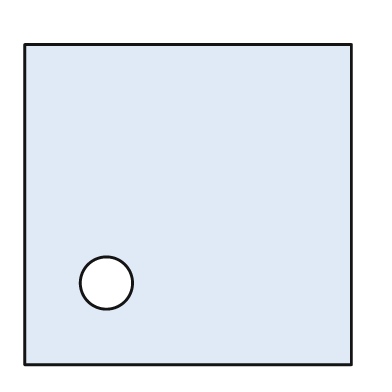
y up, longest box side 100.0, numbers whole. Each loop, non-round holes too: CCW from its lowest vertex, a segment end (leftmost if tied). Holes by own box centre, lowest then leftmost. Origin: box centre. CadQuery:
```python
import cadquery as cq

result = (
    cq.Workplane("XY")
    .moveTo(-50.0, -49.0)
    .lineTo(50.0, -49.0)
    .lineTo(50.0, 49.0)
    .lineTo(-50.0, 49.0)
    .close()
    .moveTo(-25.0, -24.0)
    .circle(8.0)
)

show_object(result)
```